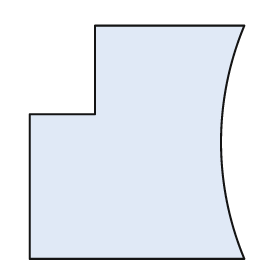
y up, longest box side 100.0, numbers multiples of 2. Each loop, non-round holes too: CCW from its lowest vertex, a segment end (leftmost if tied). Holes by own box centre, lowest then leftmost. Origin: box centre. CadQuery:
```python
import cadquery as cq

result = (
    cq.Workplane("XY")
    .moveTo(-46.0, -50.0)
    .lineTo(46.0, -50.0)
    .threePointArc((36.0, 0.0), (46.0, 50.0))
    .lineTo(-18.0, 50.0)
    .lineTo(-18.0, 12.0)
    .lineTo(-46.0, 12.0)
    .close()
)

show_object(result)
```